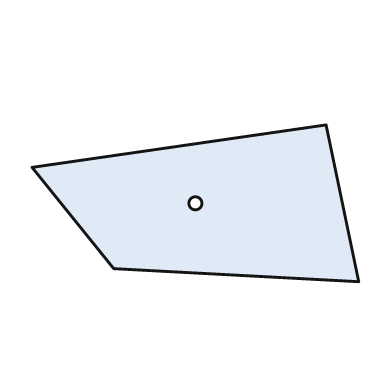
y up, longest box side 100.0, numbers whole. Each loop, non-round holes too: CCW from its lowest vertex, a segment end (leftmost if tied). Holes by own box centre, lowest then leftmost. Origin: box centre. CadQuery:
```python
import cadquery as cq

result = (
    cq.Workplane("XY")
    .moveTo(50.0, -24.0)
    .lineTo(40.0, 24.0)
    .lineTo(-50.0, 11.0)
    .lineTo(-25.0, -20.0)
    .close()
    .moveTo(0.0, 0.0)
    .circle(2.0)
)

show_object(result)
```